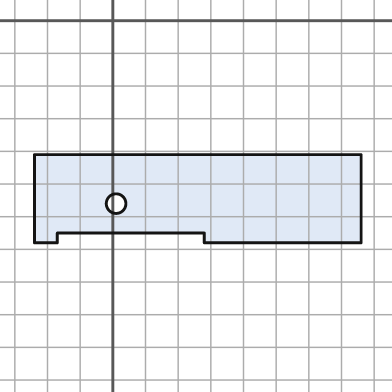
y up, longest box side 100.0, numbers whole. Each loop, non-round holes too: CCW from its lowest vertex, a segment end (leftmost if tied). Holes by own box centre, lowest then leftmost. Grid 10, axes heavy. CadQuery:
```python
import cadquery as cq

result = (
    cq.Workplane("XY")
    .moveTo(-24.0, -68.0)
    .lineTo(-17.0, -68.0)
    .lineTo(-17.0, -65.0)
    .lineTo(28.0, -65.0)
    .lineTo(28.0, -68.0)
    .lineTo(76.0, -68.0)
    .lineTo(76.0, -41.0)
    .lineTo(-24.0, -41.0)
    .close()
    .moveTo(1.0, -56.0)
    .circle(3.0)
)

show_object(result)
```